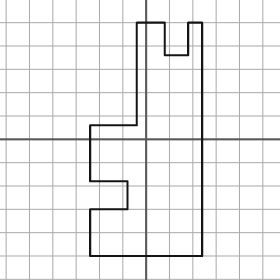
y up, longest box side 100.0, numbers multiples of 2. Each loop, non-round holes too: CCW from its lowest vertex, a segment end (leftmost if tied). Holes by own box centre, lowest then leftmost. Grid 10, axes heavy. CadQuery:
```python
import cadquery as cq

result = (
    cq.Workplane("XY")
    .moveTo(-24.0, -50.0)
    .lineTo(24.0, -50.0)
    .lineTo(24.0, 50.0)
    .lineTo(18.0, 50.0)
    .lineTo(18.0, 36.0)
    .lineTo(8.0, 36.0)
    .lineTo(8.0, 50.0)
    .lineTo(-4.0, 50.0)
    .lineTo(-4.0, 6.0)
    .lineTo(-24.0, 6.0)
    .lineTo(-24.0, -18.0)
    .lineTo(-8.0, -18.0)
    .lineTo(-8.0, -30.0)
    .lineTo(-24.0, -30.0)
    .close()
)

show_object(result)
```